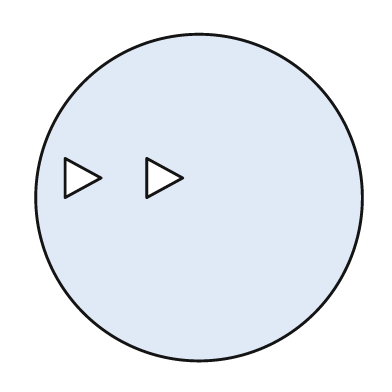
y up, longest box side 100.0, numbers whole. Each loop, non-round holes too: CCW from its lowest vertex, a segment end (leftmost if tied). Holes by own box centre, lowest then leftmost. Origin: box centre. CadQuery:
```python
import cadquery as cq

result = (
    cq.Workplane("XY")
    .moveTo(0.0, 0.0)
    .circle(50.0)
    .moveTo(-41.0, 0.0)
    .lineTo(-30.0, 6.0)
    .lineTo(-41.0, 12.0)
    .close()
    .moveTo(-16.0, 0.0)
    .lineTo(-5.0, 6.0)
    .lineTo(-16.0, 12.0)
    .close()
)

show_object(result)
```